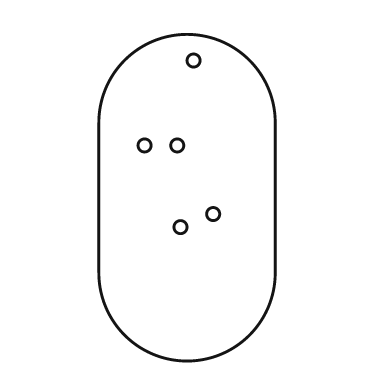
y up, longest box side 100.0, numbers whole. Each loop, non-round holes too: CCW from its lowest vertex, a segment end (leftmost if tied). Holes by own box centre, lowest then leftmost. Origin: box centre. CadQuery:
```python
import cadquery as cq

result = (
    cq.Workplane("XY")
    .moveTo(-27.0, -23.0)
    .threePointArc((0.0, -50.0), (27.0, -23.0))
    .lineTo(27.0, 23.0)
    .threePointArc((0.0, 50.0), (-27.0, 23.0))
    .close()
    .moveTo(-2.0, -9.0)
    .circle(2.0)
    .moveTo(8.0, -5.0)
    .circle(2.0)
    .moveTo(-13.0, 16.0)
    .circle(2.0)
    .moveTo(-3.0, 16.0)
    .circle(2.0)
    .moveTo(2.0, 42.0)
    .circle(2.0)
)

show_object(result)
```